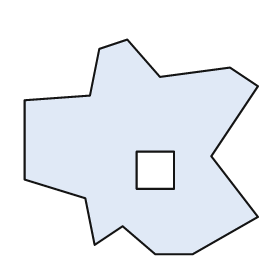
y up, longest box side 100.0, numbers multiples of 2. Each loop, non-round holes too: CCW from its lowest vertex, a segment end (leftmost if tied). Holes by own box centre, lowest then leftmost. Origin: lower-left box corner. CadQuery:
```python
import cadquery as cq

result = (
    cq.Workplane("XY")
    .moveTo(56.0, 0.0)
    .lineTo(72.0, 0.0)
    .lineTo(100.0, 16.0)
    .lineTo(80.0, 42.0)
    .lineTo(100.0, 72.0)
    .lineTo(88.0, 80.0)
    .lineTo(58.0, 76.0)
    .lineTo(44.0, 92.0)
    .lineTo(32.0, 88.0)
    .lineTo(28.0, 68.0)
    .lineTo(0.0, 66.0)
    .lineTo(0.0, 32.0)
    .lineTo(26.0, 24.0)
    .lineTo(30.0, 4.0)
    .lineTo(42.0, 12.0)
    .close()
    .moveTo(48.0, 28.0)
    .lineTo(64.0, 28.0)
    .lineTo(64.0, 44.0)
    .lineTo(48.0, 44.0)
    .close()
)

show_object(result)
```